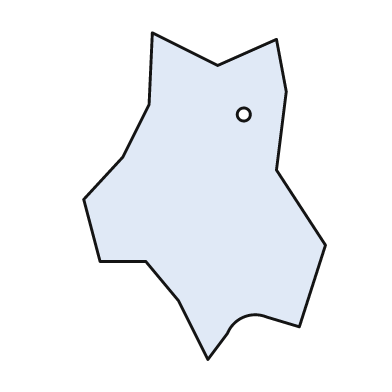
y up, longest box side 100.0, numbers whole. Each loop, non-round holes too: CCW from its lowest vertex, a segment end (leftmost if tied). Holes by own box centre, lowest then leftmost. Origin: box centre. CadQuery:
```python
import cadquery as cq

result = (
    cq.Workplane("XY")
    .moveTo(1.0, -50.0)
    .lineTo(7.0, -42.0)
    .threePointArc((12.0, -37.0), (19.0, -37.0))
    .lineTo(29.0, -40.0)
    .lineTo(37.0, -15.0)
    .lineTo(22.0, 8.0)
    .lineTo(25.0, 32.0)
    .lineTo(22.0, 48.0)
    .lineTo(4.0, 40.0)
    .lineTo(-16.0, 50.0)
    .lineTo(-17.0, 28.0)
    .lineTo(-25.0, 12.0)
    .lineTo(-37.0, -1.0)
    .lineTo(-32.0, -20.0)
    .lineTo(-18.0, -20.0)
    .lineTo(-8.0, -32.0)
    .close()
    .moveTo(12.0, 25.0)
    .circle(2.0)
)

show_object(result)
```